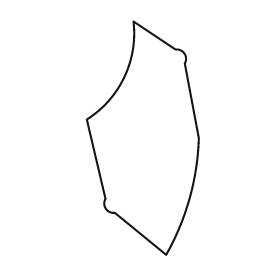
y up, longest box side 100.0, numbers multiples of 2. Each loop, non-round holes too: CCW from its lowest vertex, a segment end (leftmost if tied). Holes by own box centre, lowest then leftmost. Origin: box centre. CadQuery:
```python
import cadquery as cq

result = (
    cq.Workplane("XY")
    .moveTo(10.0, -50.0)
    .threePointArc((20.0, -26.0), (24.0, 0.0))
    .lineTo(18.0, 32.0)
    .threePointArc((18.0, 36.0), (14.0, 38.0))
    .lineTo(-4.0, 50.0)
    .threePointArc((-8.0, 26.0), (-24.0, 8.0))
    .lineTo(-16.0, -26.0)
    .threePointArc((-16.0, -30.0), (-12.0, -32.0))
    .close()
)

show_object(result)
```